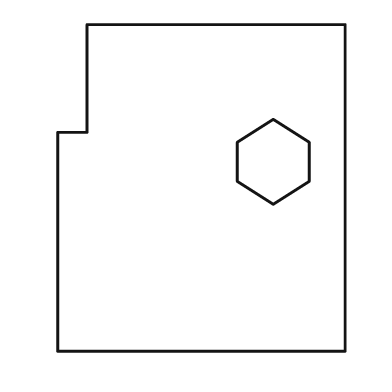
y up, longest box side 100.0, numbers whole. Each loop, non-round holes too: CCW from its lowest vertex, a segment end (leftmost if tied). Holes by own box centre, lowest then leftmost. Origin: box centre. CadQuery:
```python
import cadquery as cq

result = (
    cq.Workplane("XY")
    .moveTo(-44.0, -50.0)
    .lineTo(44.0, -50.0)
    .lineTo(44.0, 50.0)
    .lineTo(-35.0, 50.0)
    .lineTo(-35.0, 17.0)
    .lineTo(-44.0, 17.0)
    .close()
    .moveTo(22.0, -5.0)
    .lineTo(33.0, 2.0)
    .lineTo(33.0, 14.0)
    .lineTo(22.0, 21.0)
    .lineTo(11.0, 14.0)
    .lineTo(11.0, 2.0)
    .close()
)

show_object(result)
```